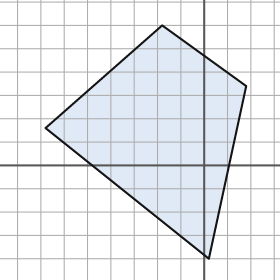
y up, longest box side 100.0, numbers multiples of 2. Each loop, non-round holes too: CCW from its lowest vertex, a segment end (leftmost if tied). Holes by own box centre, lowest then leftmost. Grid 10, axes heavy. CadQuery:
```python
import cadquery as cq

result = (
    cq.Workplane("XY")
    .moveTo(2.0, -40.0)
    .lineTo(18.0, 34.0)
    .lineTo(-18.0, 60.0)
    .lineTo(-68.0, 16.0)
    .close()
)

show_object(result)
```